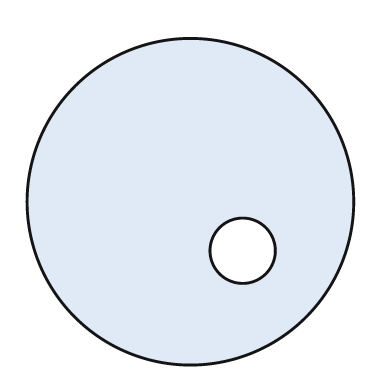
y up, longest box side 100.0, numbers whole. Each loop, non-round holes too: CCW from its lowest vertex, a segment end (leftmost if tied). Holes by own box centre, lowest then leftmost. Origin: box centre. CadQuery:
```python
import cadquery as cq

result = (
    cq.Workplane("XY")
    .moveTo(0.0, 0.0)
    .circle(50.0)
    .moveTo(16.0, -15.0)
    .circle(10.0)
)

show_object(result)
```